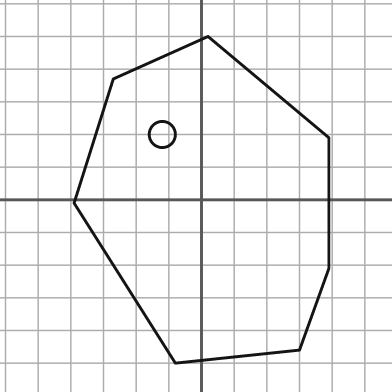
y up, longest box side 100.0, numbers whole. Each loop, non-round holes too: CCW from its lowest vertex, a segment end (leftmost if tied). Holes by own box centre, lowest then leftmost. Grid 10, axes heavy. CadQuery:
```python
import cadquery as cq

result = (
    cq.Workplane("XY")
    .moveTo(-8.0, -50.0)
    .lineTo(30.0, -46.0)
    .lineTo(39.0, -21.0)
    .lineTo(39.0, 19.0)
    .lineTo(2.0, 50.0)
    .lineTo(-27.0, 37.0)
    .lineTo(-39.0, -1.0)
    .close()
    .moveTo(-12.0, 20.0)
    .circle(4.0)
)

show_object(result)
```